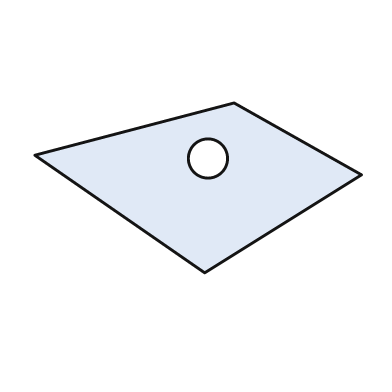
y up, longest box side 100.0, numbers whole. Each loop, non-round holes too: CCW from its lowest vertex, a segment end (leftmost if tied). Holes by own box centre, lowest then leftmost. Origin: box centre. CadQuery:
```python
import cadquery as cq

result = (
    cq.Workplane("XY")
    .moveTo(2.0, -26.0)
    .lineTo(50.0, 4.0)
    .lineTo(11.0, 26.0)
    .lineTo(-50.0, 10.0)
    .close()
    .moveTo(3.0, 9.0)
    .circle(6.0)
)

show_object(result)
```